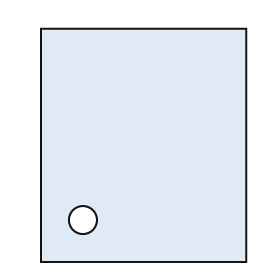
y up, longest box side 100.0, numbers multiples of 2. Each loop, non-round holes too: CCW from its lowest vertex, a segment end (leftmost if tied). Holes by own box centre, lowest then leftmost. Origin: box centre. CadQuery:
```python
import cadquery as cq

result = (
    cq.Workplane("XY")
    .moveTo(-44.0, -50.0)
    .lineTo(44.0, -50.0)
    .lineTo(44.0, 50.0)
    .lineTo(-44.0, 50.0)
    .close()
    .moveTo(-26.0, -32.0)
    .circle(6.0)
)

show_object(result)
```